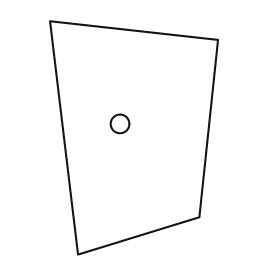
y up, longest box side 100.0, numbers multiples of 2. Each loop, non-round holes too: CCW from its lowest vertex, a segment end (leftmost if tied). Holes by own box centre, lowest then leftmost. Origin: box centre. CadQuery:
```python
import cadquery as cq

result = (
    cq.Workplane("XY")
    .moveTo(-24.0, -50.0)
    .lineTo(28.0, -34.0)
    .lineTo(36.0, 42.0)
    .lineTo(-36.0, 50.0)
    .close()
    .moveTo(-6.0, 6.0)
    .circle(4.0)
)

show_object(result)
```